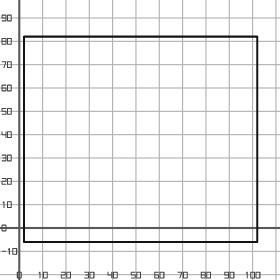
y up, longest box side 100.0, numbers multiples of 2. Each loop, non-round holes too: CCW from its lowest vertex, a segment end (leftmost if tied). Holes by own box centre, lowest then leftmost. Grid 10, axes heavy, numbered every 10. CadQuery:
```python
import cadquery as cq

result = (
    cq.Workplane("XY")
    .moveTo(2.0, -6.0)
    .lineTo(102.0, -6.0)
    .lineTo(102.0, 82.0)
    .lineTo(2.0, 82.0)
    .close()
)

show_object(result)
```